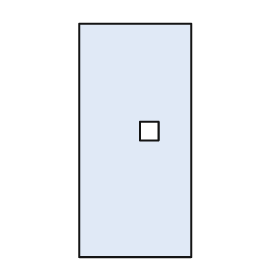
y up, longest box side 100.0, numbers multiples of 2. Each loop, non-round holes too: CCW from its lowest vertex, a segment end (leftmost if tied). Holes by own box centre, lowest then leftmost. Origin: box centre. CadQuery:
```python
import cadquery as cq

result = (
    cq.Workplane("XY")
    .moveTo(-24.0, -50.0)
    .lineTo(24.0, -50.0)
    .lineTo(24.0, 50.0)
    .lineTo(-24.0, 50.0)
    .close()
    .moveTo(2.0, 0.0)
    .lineTo(10.0, 0.0)
    .lineTo(10.0, 8.0)
    .lineTo(2.0, 8.0)
    .close()
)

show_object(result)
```